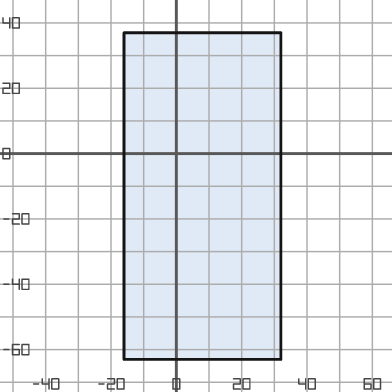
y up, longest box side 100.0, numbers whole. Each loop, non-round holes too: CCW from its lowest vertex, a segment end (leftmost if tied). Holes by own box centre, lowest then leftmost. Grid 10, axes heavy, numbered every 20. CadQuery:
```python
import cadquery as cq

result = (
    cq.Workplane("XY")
    .moveTo(-16.0, -63.0)
    .lineTo(32.0, -63.0)
    .lineTo(32.0, 37.0)
    .lineTo(-16.0, 37.0)
    .close()
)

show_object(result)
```